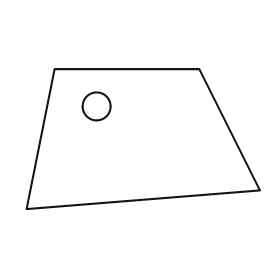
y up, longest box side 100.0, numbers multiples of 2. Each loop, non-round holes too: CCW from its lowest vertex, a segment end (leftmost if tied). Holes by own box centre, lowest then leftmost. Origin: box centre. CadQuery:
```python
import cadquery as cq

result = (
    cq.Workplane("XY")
    .moveTo(-50.0, -30.0)
    .lineTo(50.0, -22.0)
    .lineTo(24.0, 30.0)
    .lineTo(-38.0, 30.0)
    .close()
    .moveTo(-20.0, 14.0)
    .circle(6.0)
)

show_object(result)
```